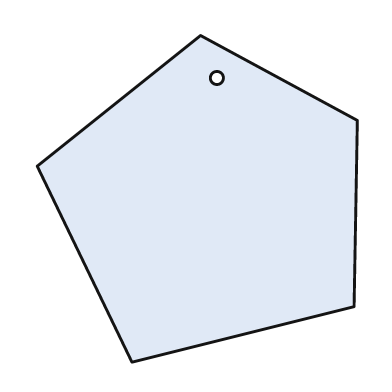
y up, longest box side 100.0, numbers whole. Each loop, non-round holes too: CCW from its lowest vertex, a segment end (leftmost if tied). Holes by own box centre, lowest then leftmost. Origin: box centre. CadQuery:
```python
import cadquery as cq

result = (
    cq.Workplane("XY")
    .moveTo(-20.0, -50.0)
    .lineTo(48.0, -33.0)
    .lineTo(49.0, 24.0)
    .lineTo(1.0, 50.0)
    .lineTo(-49.0, 10.0)
    .close()
    .moveTo(6.0, 37.0)
    .circle(2.0)
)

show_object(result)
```